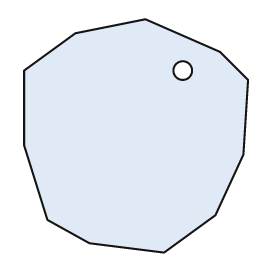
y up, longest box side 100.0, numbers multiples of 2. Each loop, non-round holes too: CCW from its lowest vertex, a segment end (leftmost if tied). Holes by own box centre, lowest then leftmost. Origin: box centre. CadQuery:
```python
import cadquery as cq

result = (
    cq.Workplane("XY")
    .moveTo(12.0, -50.0)
    .lineTo(34.0, -34.0)
    .lineTo(46.0, -8.0)
    .lineTo(48.0, 24.0)
    .lineTo(36.0, 36.0)
    .lineTo(4.0, 50.0)
    .lineTo(-26.0, 44.0)
    .lineTo(-48.0, 28.0)
    .lineTo(-48.0, -4.0)
    .lineTo(-38.0, -36.0)
    .lineTo(-20.0, -46.0)
    .close()
    .moveTo(20.0, 28.0)
    .circle(4.0)
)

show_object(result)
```